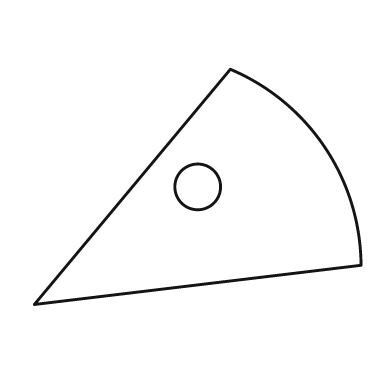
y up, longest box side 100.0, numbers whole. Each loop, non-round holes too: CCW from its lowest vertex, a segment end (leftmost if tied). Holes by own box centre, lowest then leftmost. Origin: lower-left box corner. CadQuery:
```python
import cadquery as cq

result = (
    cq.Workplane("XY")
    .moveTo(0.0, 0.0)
    .lineTo(100.0, 12.0)
    .threePointArc((89.0, 48.0), (60.0, 72.0))
    .close()
    .moveTo(50.0, 36.0)
    .circle(7.0)
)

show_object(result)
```